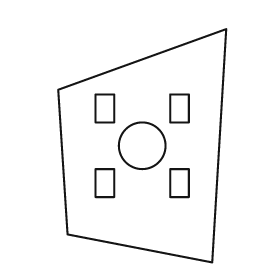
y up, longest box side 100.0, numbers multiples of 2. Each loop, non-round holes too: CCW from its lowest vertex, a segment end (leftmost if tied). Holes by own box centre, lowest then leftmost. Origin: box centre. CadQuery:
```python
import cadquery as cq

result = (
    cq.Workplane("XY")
    .moveTo(30.0, -50.0)
    .lineTo(36.0, 50.0)
    .lineTo(-36.0, 24.0)
    .lineTo(-32.0, -38.0)
    .close()
    .moveTo(-20.0, -22.0)
    .lineTo(-12.0, -22.0)
    .lineTo(-12.0, -10.0)
    .lineTo(-20.0, -10.0)
    .close()
    .moveTo(12.0, -22.0)
    .lineTo(20.0, -22.0)
    .lineTo(20.0, -10.0)
    .lineTo(12.0, -10.0)
    .close()
    .moveTo(0.0, 0.0)
    .circle(10.0)
    .moveTo(-20.0, 10.0)
    .lineTo(-12.0, 10.0)
    .lineTo(-12.0, 22.0)
    .lineTo(-20.0, 22.0)
    .close()
    .moveTo(12.0, 10.0)
    .lineTo(20.0, 10.0)
    .lineTo(20.0, 22.0)
    .lineTo(12.0, 22.0)
    .close()
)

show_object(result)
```